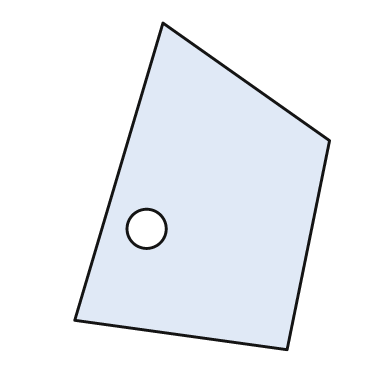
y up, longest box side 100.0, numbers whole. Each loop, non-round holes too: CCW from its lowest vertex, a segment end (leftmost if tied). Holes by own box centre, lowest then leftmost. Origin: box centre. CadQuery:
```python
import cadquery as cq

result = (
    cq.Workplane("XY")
    .moveTo(26.0, -50.0)
    .lineTo(39.0, 14.0)
    .lineTo(-12.0, 50.0)
    .lineTo(-39.0, -41.0)
    .close()
    .moveTo(-17.0, -13.0)
    .circle(6.0)
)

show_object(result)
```